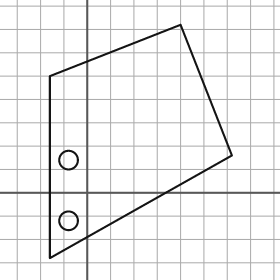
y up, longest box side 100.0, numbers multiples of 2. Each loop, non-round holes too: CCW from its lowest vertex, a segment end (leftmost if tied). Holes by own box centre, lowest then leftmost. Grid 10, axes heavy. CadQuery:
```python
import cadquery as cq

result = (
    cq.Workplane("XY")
    .moveTo(-16.0, -28.0)
    .lineTo(62.0, 16.0)
    .lineTo(40.0, 72.0)
    .lineTo(-16.0, 50.0)
    .close()
    .moveTo(-8.0, -12.0)
    .circle(4.0)
    .moveTo(-8.0, 14.0)
    .circle(4.0)
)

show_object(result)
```